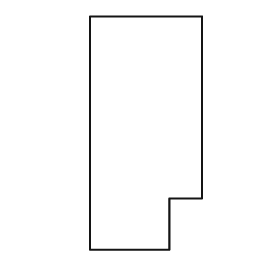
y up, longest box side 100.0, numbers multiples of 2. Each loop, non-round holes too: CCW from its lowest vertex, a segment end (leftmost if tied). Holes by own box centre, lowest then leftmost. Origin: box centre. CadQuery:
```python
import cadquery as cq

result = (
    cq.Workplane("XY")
    .moveTo(-24.0, -50.0)
    .lineTo(10.0, -50.0)
    .lineTo(10.0, -28.0)
    .lineTo(24.0, -28.0)
    .lineTo(24.0, 50.0)
    .lineTo(-24.0, 50.0)
    .close()
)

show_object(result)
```